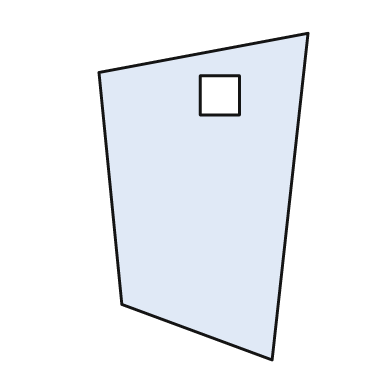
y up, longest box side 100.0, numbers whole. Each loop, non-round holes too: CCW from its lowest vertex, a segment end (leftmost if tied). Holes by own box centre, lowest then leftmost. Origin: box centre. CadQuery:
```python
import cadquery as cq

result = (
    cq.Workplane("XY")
    .moveTo(21.0, -50.0)
    .lineTo(32.0, 50.0)
    .lineTo(-32.0, 38.0)
    .lineTo(-25.0, -33.0)
    .close()
    .moveTo(-1.0, 25.0)
    .lineTo(11.0, 25.0)
    .lineTo(11.0, 37.0)
    .lineTo(-1.0, 37.0)
    .close()
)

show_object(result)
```